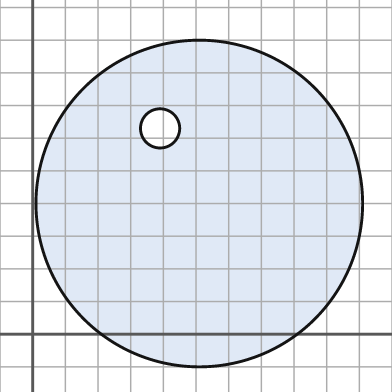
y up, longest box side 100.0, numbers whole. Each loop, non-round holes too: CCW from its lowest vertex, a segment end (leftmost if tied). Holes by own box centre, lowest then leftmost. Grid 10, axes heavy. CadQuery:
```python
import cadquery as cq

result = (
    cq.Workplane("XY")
    .moveTo(51.0, 40.0)
    .circle(50.0)
    .moveTo(39.0, 63.0)
    .circle(6.0)
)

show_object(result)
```